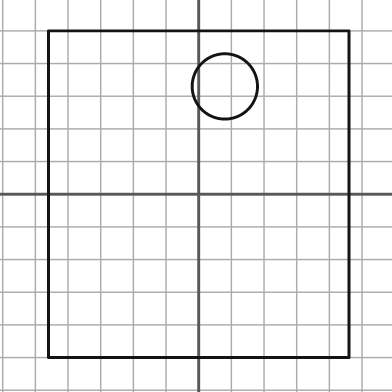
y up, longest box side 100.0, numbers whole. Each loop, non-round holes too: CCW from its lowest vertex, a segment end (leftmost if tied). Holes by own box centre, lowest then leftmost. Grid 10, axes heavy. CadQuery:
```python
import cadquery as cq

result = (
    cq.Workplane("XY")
    .moveTo(-46.0, -50.0)
    .lineTo(46.0, -50.0)
    .lineTo(46.0, 50.0)
    .lineTo(-46.0, 50.0)
    .close()
    .moveTo(8.0, 33.0)
    .circle(10.0)
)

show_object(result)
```